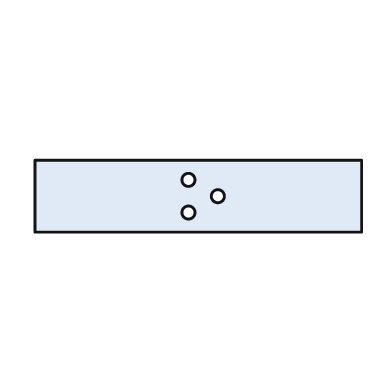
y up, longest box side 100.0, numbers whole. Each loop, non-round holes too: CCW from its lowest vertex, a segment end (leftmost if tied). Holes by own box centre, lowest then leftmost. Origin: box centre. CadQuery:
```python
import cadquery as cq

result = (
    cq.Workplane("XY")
    .moveTo(-50.0, -11.0)
    .lineTo(50.0, -11.0)
    .lineTo(50.0, 11.0)
    .lineTo(-50.0, 11.0)
    .close()
    .moveTo(-3.0, -5.0)
    .circle(2.0)
    .moveTo(6.0, 0.0)
    .circle(2.0)
    .moveTo(-3.0, 5.0)
    .circle(2.0)
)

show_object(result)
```